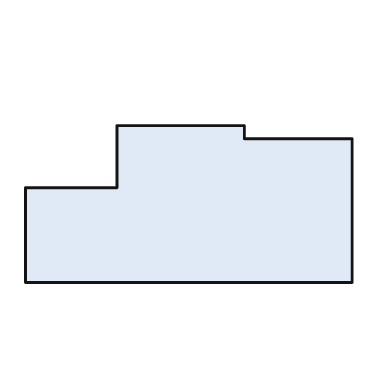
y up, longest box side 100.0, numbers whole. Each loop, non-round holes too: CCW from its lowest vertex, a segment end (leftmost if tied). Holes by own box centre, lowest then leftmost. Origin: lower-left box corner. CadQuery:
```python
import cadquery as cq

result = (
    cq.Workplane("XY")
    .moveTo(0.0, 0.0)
    .lineTo(100.0, 0.0)
    .lineTo(100.0, 44.0)
    .lineTo(67.0, 44.0)
    .lineTo(67.0, 48.0)
    .lineTo(28.0, 48.0)
    .lineTo(28.0, 29.0)
    .lineTo(0.0, 29.0)
    .close()
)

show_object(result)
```